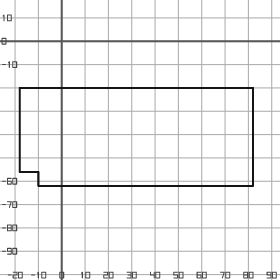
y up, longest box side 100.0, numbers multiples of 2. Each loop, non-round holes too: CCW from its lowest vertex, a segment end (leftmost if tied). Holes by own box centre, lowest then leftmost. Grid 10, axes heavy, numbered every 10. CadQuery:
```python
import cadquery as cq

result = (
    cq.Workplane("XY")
    .moveTo(-10.0, -62.0)
    .lineTo(82.0, -62.0)
    .lineTo(82.0, -20.0)
    .lineTo(-18.0, -20.0)
    .lineTo(-18.0, -56.0)
    .lineTo(-10.0, -56.0)
    .close()
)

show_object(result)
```